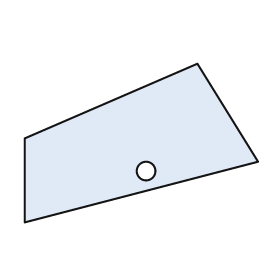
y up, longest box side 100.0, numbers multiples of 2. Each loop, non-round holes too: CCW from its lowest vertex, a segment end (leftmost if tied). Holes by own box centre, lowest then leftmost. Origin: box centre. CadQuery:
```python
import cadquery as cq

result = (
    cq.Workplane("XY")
    .moveTo(-50.0, -34.0)
    .lineTo(50.0, -8.0)
    .lineTo(24.0, 34.0)
    .lineTo(-50.0, 2.0)
    .close()
    .moveTo(2.0, -12.0)
    .circle(4.0)
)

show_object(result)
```